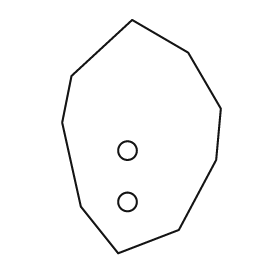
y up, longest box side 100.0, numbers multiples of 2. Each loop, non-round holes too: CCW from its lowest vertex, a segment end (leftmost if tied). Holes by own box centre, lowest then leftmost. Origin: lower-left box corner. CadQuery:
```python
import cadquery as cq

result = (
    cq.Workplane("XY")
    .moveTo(24.0, 0.0)
    .lineTo(50.0, 10.0)
    .lineTo(66.0, 40.0)
    .lineTo(68.0, 62.0)
    .lineTo(54.0, 86.0)
    .lineTo(30.0, 100.0)
    .lineTo(4.0, 76.0)
    .lineTo(0.0, 56.0)
    .lineTo(8.0, 20.0)
    .close()
    .moveTo(28.0, 22.0)
    .circle(4.0)
    .moveTo(28.0, 44.0)
    .circle(4.0)
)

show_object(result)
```